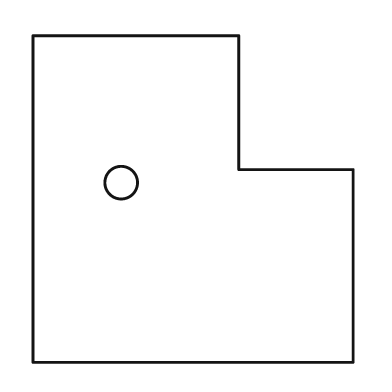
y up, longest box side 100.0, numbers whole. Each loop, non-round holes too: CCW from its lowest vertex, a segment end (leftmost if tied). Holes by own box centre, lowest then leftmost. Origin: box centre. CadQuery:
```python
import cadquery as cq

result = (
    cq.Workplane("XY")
    .moveTo(-49.0, -50.0)
    .lineTo(49.0, -50.0)
    .lineTo(49.0, 9.0)
    .lineTo(14.0, 9.0)
    .lineTo(14.0, 50.0)
    .lineTo(-49.0, 50.0)
    .close()
    .moveTo(-22.0, 5.0)
    .circle(5.0)
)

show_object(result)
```